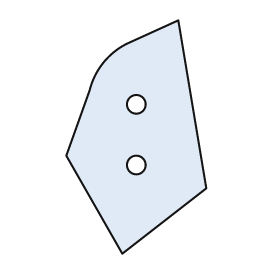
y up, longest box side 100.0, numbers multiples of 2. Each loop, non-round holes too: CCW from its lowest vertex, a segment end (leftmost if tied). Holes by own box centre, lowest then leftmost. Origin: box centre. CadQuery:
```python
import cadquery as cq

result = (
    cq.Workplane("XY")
    .moveTo(-6.0, -50.0)
    .lineTo(30.0, -22.0)
    .lineTo(18.0, 50.0)
    .lineTo(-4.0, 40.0)
    .threePointArc((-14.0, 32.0), (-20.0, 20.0))
    .lineTo(-30.0, -8.0)
    .close()
    .moveTo(0.0, -12.0)
    .circle(4.0)
    .moveTo(0.0, 14.0)
    .circle(4.0)
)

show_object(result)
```